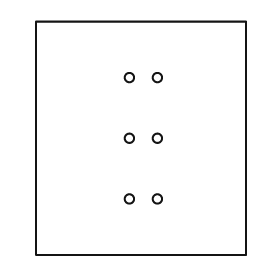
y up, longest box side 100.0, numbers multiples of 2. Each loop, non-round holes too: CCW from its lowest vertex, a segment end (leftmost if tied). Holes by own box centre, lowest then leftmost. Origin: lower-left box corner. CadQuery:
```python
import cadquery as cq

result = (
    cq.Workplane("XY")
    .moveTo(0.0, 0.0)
    .lineTo(90.0, 0.0)
    .lineTo(90.0, 100.0)
    .lineTo(0.0, 100.0)
    .close()
    .moveTo(40.0, 24.0)
    .circle(2.0)
    .moveTo(52.0, 24.0)
    .circle(2.0)
    .moveTo(40.0, 50.0)
    .circle(2.0)
    .moveTo(52.0, 50.0)
    .circle(2.0)
    .moveTo(40.0, 76.0)
    .circle(2.0)
    .moveTo(52.0, 76.0)
    .circle(2.0)
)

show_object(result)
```